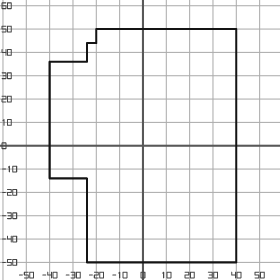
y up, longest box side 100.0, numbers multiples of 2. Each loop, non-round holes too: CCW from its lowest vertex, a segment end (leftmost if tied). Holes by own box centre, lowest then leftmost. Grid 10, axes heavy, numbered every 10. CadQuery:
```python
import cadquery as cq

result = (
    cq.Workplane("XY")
    .moveTo(-24.0, -50.0)
    .lineTo(40.0, -50.0)
    .lineTo(40.0, 50.0)
    .lineTo(-20.0, 50.0)
    .lineTo(-20.0, 44.0)
    .lineTo(-24.0, 44.0)
    .lineTo(-24.0, 36.0)
    .lineTo(-40.0, 36.0)
    .lineTo(-40.0, -14.0)
    .lineTo(-24.0, -14.0)
    .close()
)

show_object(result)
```